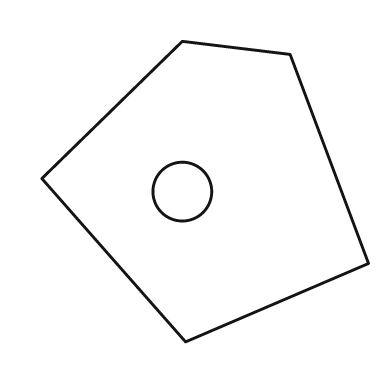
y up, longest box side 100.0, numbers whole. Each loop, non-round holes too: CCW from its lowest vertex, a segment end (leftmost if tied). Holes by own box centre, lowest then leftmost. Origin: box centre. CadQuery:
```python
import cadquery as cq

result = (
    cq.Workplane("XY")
    .moveTo(-6.0, -46.0)
    .lineTo(50.0, -22.0)
    .lineTo(26.0, 42.0)
    .lineTo(-7.0, 46.0)
    .lineTo(-50.0, 4.0)
    .close()
    .moveTo(-7.0, 0.0)
    .circle(9.0)
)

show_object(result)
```